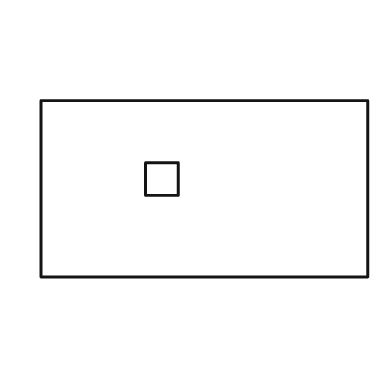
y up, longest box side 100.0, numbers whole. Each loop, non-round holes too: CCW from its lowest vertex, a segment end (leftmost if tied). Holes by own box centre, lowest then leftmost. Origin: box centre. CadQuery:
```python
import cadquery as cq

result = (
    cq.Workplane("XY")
    .moveTo(-50.0, -27.0)
    .lineTo(50.0, -27.0)
    .lineTo(50.0, 27.0)
    .lineTo(-50.0, 27.0)
    .close()
    .moveTo(-18.0, -2.0)
    .lineTo(-8.0, -2.0)
    .lineTo(-8.0, 8.0)
    .lineTo(-18.0, 8.0)
    .close()
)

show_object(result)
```